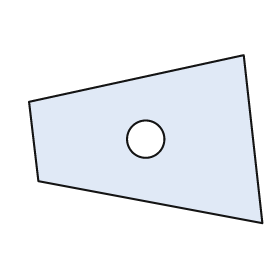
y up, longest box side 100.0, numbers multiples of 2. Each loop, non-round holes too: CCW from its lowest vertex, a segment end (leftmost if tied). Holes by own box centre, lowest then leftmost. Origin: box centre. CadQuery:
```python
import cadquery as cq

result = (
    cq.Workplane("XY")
    .moveTo(50.0, -36.0)
    .lineTo(42.0, 36.0)
    .lineTo(-50.0, 16.0)
    .lineTo(-46.0, -18.0)
    .close()
    .moveTo(0.0, 0.0)
    .circle(8.0)
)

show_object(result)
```